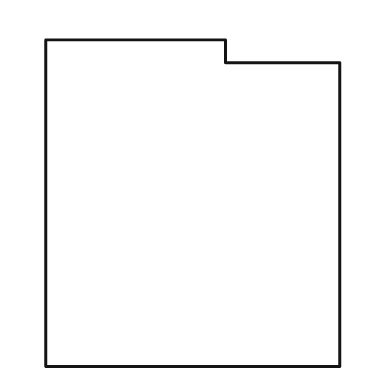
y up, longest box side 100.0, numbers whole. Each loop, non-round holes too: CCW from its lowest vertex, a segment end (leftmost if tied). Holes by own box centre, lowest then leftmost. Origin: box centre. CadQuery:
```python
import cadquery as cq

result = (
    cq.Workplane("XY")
    .moveTo(-45.0, -50.0)
    .lineTo(45.0, -50.0)
    .lineTo(45.0, 43.0)
    .lineTo(10.0, 43.0)
    .lineTo(10.0, 50.0)
    .lineTo(-45.0, 50.0)
    .close()
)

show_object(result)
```